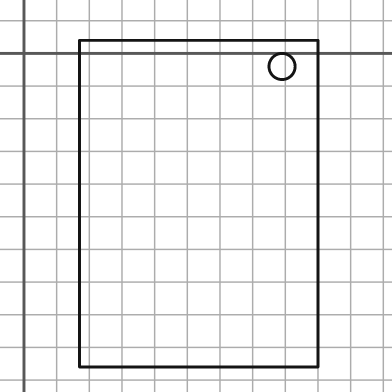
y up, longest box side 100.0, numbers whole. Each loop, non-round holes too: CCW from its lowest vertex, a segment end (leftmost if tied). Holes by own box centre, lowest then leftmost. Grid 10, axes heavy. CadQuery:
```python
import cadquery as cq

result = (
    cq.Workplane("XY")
    .moveTo(17.0, -96.0)
    .lineTo(90.0, -96.0)
    .lineTo(90.0, 4.0)
    .lineTo(17.0, 4.0)
    .close()
    .moveTo(79.0, -4.0)
    .circle(4.0)
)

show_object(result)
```